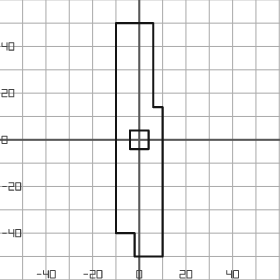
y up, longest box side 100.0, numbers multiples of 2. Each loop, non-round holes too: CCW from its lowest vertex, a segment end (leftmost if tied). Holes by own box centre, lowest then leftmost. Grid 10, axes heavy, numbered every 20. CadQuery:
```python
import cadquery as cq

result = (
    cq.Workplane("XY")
    .moveTo(-2.0, -50.0)
    .lineTo(10.0, -50.0)
    .lineTo(10.0, 14.0)
    .lineTo(6.0, 14.0)
    .lineTo(6.0, 50.0)
    .lineTo(-10.0, 50.0)
    .lineTo(-10.0, -40.0)
    .lineTo(-2.0, -40.0)
    .close()
    .moveTo(-4.0, -4.0)
    .lineTo(4.0, -4.0)
    .lineTo(4.0, 4.0)
    .lineTo(-4.0, 4.0)
    .close()
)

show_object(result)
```